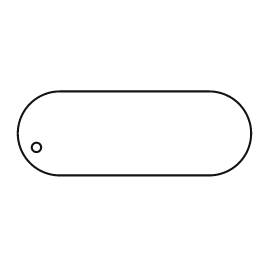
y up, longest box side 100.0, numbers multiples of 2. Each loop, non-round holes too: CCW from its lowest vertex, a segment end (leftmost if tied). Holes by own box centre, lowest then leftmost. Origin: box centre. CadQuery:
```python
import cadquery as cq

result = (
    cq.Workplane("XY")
    .moveTo(-32.0, -18.0)
    .lineTo(32.0, -18.0)
    .threePointArc((50.0, 0.0), (32.0, 18.0))
    .lineTo(-32.0, 18.0)
    .threePointArc((-50.0, 0.0), (-32.0, -18.0))
    .close()
    .moveTo(-42.0, -6.0)
    .circle(2.0)
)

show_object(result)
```